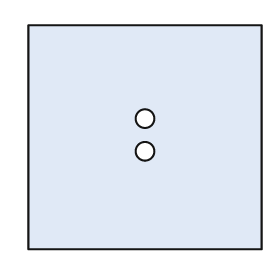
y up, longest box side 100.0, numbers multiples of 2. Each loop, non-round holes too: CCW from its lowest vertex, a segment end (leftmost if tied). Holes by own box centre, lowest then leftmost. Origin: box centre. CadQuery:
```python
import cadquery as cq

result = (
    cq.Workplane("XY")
    .moveTo(-50.0, -48.0)
    .lineTo(50.0, -48.0)
    .lineTo(50.0, 48.0)
    .lineTo(-50.0, 48.0)
    .close()
    .moveTo(0.0, -6.0)
    .circle(4.0)
    .moveTo(0.0, 8.0)
    .circle(4.0)
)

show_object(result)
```